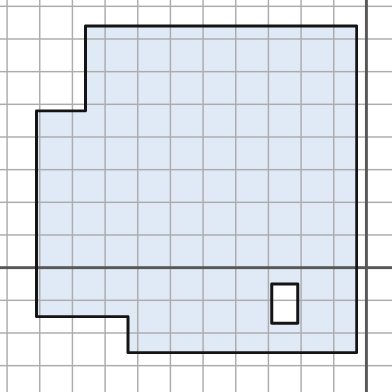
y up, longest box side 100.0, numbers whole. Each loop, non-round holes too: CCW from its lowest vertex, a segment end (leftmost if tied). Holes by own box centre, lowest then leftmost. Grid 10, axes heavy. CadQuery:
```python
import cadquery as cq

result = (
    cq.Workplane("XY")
    .moveTo(-73.0, -26.0)
    .lineTo(-3.0, -26.0)
    .lineTo(-3.0, 74.0)
    .lineTo(-86.0, 74.0)
    .lineTo(-86.0, 48.0)
    .lineTo(-101.0, 48.0)
    .lineTo(-101.0, -15.0)
    .lineTo(-73.0, -15.0)
    .close()
    .moveTo(-29.0, -17.0)
    .lineTo(-21.0, -17.0)
    .lineTo(-21.0, -5.0)
    .lineTo(-29.0, -5.0)
    .close()
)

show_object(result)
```